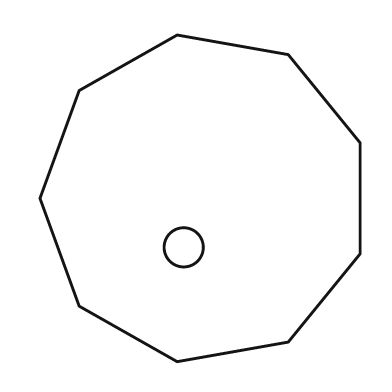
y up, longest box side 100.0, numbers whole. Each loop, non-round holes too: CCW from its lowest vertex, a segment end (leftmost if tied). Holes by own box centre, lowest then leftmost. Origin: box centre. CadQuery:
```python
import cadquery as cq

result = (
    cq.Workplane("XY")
    .moveTo(-7.0, -50.0)
    .lineTo(27.0, -44.0)
    .lineTo(49.0, -17.0)
    .lineTo(49.0, 17.0)
    .lineTo(27.0, 44.0)
    .lineTo(-7.0, 50.0)
    .lineTo(-37.0, 33.0)
    .lineTo(-49.0, 0.0)
    .lineTo(-37.0, -33.0)
    .close()
    .moveTo(-5.0, -15.0)
    .circle(6.0)
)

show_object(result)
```